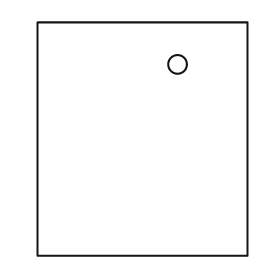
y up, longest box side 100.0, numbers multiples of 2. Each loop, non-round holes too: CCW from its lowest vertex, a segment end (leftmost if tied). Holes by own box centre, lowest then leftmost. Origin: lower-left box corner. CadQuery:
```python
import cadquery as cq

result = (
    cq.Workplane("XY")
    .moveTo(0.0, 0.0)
    .lineTo(90.0, 0.0)
    .lineTo(90.0, 100.0)
    .lineTo(0.0, 100.0)
    .close()
    .moveTo(60.0, 82.0)
    .circle(4.0)
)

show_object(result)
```